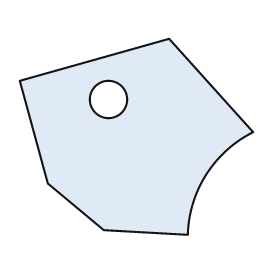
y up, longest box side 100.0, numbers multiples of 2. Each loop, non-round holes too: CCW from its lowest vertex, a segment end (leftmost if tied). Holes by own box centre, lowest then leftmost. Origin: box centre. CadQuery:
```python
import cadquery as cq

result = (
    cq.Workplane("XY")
    .moveTo(22.0, -42.0)
    .threePointArc((30.0, -16.0), (50.0, 2.0))
    .lineTo(14.0, 42.0)
    .lineTo(-50.0, 24.0)
    .lineTo(-38.0, -20.0)
    .lineTo(-14.0, -40.0)
    .close()
    .moveTo(-12.0, 16.0)
    .circle(8.0)
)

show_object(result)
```